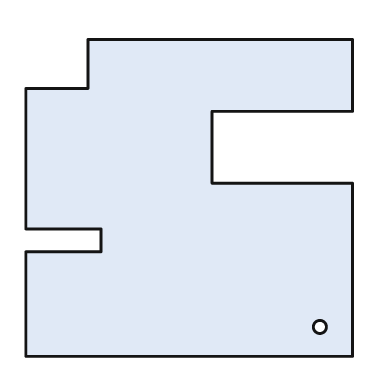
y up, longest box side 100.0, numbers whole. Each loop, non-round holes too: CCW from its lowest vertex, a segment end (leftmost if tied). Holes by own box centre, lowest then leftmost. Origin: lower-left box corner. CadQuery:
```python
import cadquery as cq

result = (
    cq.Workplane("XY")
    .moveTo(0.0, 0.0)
    .lineTo(100.0, 0.0)
    .lineTo(100.0, 53.0)
    .lineTo(57.0, 53.0)
    .lineTo(57.0, 75.0)
    .lineTo(100.0, 75.0)
    .lineTo(100.0, 97.0)
    .lineTo(19.0, 97.0)
    .lineTo(19.0, 82.0)
    .lineTo(0.0, 82.0)
    .lineTo(0.0, 39.0)
    .lineTo(23.0, 39.0)
    .lineTo(23.0, 32.0)
    .lineTo(0.0, 32.0)
    .close()
    .moveTo(90.0, 9.0)
    .circle(2.0)
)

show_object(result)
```